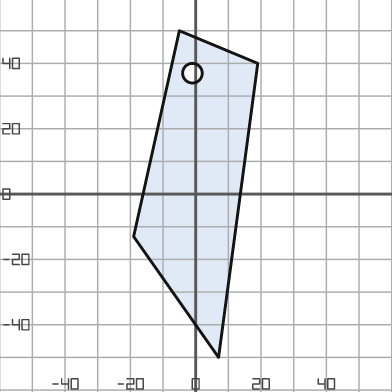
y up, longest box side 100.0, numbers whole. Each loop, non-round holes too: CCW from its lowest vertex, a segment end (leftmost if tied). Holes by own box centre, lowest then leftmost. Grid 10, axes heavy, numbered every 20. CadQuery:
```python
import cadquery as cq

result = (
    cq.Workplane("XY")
    .moveTo(7.0, -50.0)
    .lineTo(19.0, 40.0)
    .lineTo(-5.0, 50.0)
    .lineTo(-19.0, -13.0)
    .close()
    .moveTo(-1.0, 37.0)
    .circle(3.0)
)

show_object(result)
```